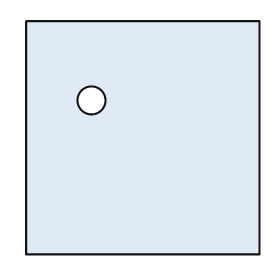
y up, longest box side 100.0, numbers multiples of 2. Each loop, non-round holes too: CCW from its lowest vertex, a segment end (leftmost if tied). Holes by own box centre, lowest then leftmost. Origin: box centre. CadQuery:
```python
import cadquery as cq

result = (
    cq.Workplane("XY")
    .moveTo(-50.0, -50.0)
    .lineTo(50.0, -50.0)
    .lineTo(50.0, 50.0)
    .lineTo(-50.0, 50.0)
    .close()
    .moveTo(-22.0, 16.0)
    .circle(6.0)
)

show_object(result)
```